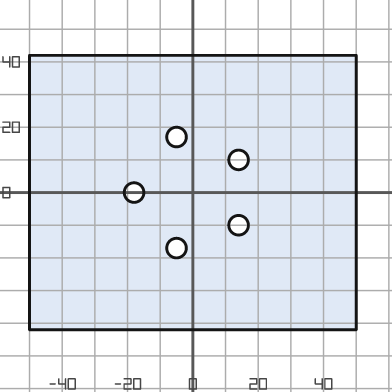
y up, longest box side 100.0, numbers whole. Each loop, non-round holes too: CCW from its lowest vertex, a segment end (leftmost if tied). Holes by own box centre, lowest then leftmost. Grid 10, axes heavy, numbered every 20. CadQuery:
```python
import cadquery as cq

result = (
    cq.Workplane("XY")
    .moveTo(-50.0, -42.0)
    .lineTo(50.0, -42.0)
    .lineTo(50.0, 42.0)
    .lineTo(-50.0, 42.0)
    .close()
    .moveTo(-5.0, -17.0)
    .circle(3.0)
    .moveTo(14.0, -10.0)
    .circle(3.0)
    .moveTo(-18.0, 0.0)
    .circle(3.0)
    .moveTo(14.0, 10.0)
    .circle(3.0)
    .moveTo(-5.0, 17.0)
    .circle(3.0)
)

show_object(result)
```